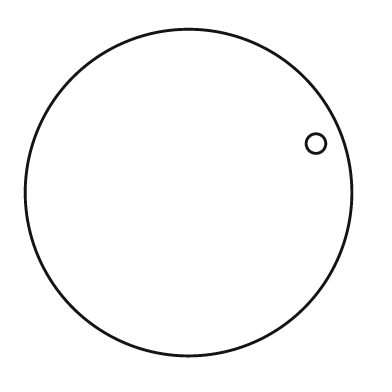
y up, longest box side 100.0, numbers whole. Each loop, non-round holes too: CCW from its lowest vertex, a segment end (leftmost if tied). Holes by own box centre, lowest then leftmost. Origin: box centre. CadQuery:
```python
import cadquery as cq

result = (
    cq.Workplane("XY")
    .moveTo(0.0, 0.0)
    .circle(50.0)
    .moveTo(39.0, 15.0)
    .circle(3.0)
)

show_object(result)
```